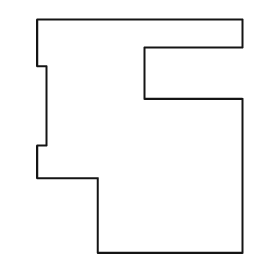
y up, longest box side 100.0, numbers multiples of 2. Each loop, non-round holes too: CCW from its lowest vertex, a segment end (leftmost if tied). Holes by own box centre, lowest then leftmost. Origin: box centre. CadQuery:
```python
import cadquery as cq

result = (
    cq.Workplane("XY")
    .moveTo(-18.0, -50.0)
    .lineTo(44.0, -50.0)
    .lineTo(44.0, 16.0)
    .lineTo(2.0, 16.0)
    .lineTo(2.0, 38.0)
    .lineTo(44.0, 38.0)
    .lineTo(44.0, 50.0)
    .lineTo(-44.0, 50.0)
    .lineTo(-44.0, 30.0)
    .lineTo(-40.0, 30.0)
    .lineTo(-40.0, -4.0)
    .lineTo(-44.0, -4.0)
    .lineTo(-44.0, -18.0)
    .lineTo(-18.0, -18.0)
    .close()
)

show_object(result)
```